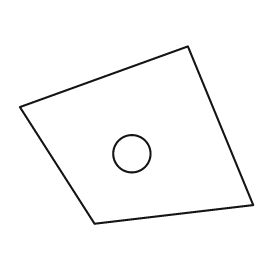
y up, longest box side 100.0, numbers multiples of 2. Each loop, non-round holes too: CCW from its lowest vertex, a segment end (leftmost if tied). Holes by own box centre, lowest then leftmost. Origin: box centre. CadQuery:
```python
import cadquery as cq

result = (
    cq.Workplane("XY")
    .moveTo(-18.0, -38.0)
    .lineTo(50.0, -30.0)
    .lineTo(22.0, 38.0)
    .lineTo(-50.0, 12.0)
    .close()
    .moveTo(-2.0, -8.0)
    .circle(8.0)
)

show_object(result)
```